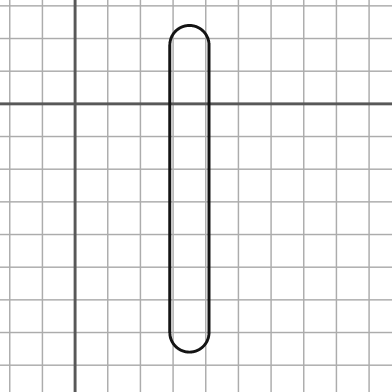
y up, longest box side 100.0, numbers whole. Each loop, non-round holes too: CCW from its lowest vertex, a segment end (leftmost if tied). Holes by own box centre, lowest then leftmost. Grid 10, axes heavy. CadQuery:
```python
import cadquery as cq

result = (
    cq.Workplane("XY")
    .moveTo(29.0, -70.0)
    .threePointArc((35.0, -76.0), (41.0, -70.0))
    .lineTo(41.0, 18.0)
    .threePointArc((35.0, 24.0), (29.0, 18.0))
    .close()
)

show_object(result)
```